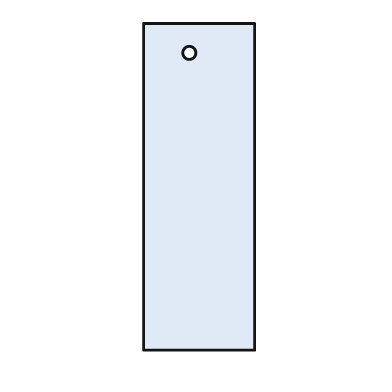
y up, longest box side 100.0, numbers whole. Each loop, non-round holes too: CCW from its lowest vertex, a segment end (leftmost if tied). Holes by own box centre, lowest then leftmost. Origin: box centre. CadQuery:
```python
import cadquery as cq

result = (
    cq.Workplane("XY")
    .moveTo(-17.0, -50.0)
    .lineTo(17.0, -50.0)
    .lineTo(17.0, 50.0)
    .lineTo(-17.0, 50.0)
    .close()
    .moveTo(-3.0, 41.0)
    .circle(2.0)
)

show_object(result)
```